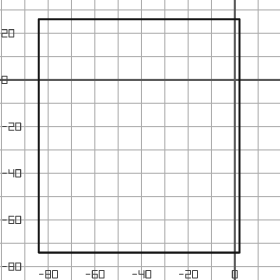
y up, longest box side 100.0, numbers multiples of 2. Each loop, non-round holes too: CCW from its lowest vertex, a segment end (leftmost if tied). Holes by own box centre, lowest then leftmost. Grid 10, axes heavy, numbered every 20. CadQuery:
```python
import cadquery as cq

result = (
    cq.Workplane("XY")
    .moveTo(-84.0, -74.0)
    .lineTo(2.0, -74.0)
    .lineTo(2.0, 26.0)
    .lineTo(-84.0, 26.0)
    .close()
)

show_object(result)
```